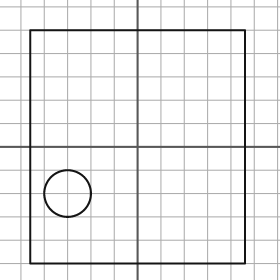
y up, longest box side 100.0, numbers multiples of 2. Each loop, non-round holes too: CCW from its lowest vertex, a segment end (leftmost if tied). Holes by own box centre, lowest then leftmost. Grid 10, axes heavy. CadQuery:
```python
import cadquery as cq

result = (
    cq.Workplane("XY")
    .moveTo(-46.0, -50.0)
    .lineTo(46.0, -50.0)
    .lineTo(46.0, 50.0)
    .lineTo(-46.0, 50.0)
    .close()
    .moveTo(-30.0, -20.0)
    .circle(10.0)
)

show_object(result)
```